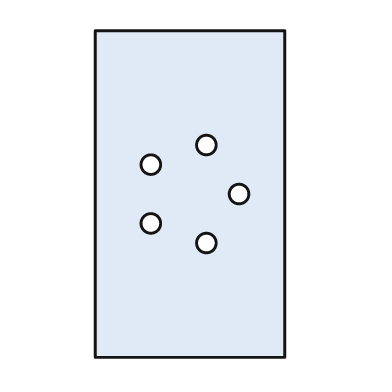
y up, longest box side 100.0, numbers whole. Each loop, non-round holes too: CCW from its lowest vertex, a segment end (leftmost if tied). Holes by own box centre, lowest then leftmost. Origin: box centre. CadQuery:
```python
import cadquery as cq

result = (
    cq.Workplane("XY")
    .moveTo(-29.0, -50.0)
    .lineTo(29.0, -50.0)
    .lineTo(29.0, 50.0)
    .lineTo(-29.0, 50.0)
    .close()
    .moveTo(5.0, -15.0)
    .circle(3.0)
    .moveTo(-12.0, -9.0)
    .circle(3.0)
    .moveTo(15.0, 0.0)
    .circle(3.0)
    .moveTo(-12.0, 9.0)
    .circle(3.0)
    .moveTo(5.0, 15.0)
    .circle(3.0)
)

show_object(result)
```